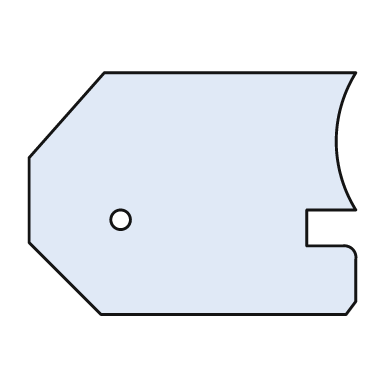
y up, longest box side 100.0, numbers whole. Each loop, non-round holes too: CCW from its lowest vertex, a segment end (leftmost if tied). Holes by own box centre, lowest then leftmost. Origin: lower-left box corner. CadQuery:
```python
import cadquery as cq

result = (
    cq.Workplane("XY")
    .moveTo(22.0, 0.0)
    .lineTo(97.0, 0.0)
    .lineTo(100.0, 4.0)
    .lineTo(100.0, 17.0)
    .threePointArc((99.0, 20.0), (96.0, 21.0))
    .lineTo(85.0, 21.0)
    .lineTo(85.0, 32.0)
    .lineTo(100.0, 32.0)
    .threePointArc((94.0, 53.0), (100.0, 74.0))
    .lineTo(23.0, 74.0)
    .lineTo(0.0, 48.0)
    .lineTo(0.0, 22.0)
    .close()
    .moveTo(28.0, 29.0)
    .circle(3.0)
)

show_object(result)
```